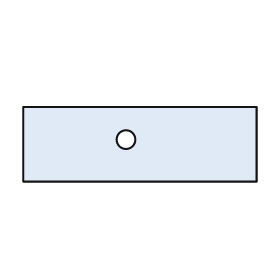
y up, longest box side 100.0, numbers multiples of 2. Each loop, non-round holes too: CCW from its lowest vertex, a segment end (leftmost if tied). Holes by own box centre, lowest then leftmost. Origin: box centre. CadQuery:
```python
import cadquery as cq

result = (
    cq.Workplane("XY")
    .moveTo(-50.0, -16.0)
    .lineTo(50.0, -16.0)
    .lineTo(50.0, 16.0)
    .lineTo(-50.0, 16.0)
    .close()
    .moveTo(-6.0, 2.0)
    .circle(4.0)
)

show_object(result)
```